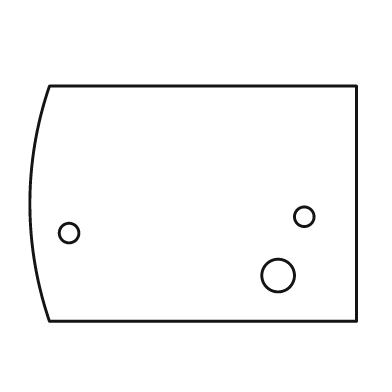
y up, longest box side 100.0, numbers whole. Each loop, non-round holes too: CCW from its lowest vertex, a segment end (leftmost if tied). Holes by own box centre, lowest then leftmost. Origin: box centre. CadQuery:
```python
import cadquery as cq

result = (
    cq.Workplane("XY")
    .moveTo(-44.0, -36.0)
    .lineTo(50.0, -36.0)
    .lineTo(50.0, 36.0)
    .lineTo(-44.0, 36.0)
    .threePointArc((-50.0, 0.0), (-44.0, -36.0))
    .close()
    .moveTo(26.0, -22.0)
    .circle(5.0)
    .moveTo(-38.0, -9.0)
    .circle(3.0)
    .moveTo(34.0, -4.0)
    .circle(3.0)
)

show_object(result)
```